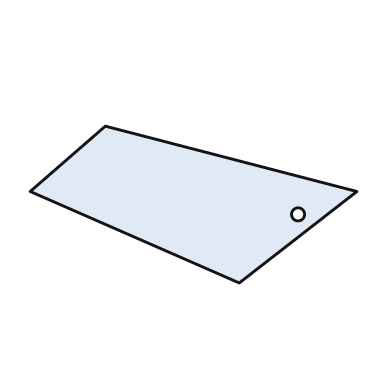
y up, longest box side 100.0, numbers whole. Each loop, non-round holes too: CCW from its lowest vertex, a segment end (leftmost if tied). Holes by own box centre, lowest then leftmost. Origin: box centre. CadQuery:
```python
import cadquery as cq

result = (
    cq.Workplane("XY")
    .moveTo(14.0, -24.0)
    .lineTo(50.0, 4.0)
    .lineTo(-27.0, 24.0)
    .lineTo(-50.0, 4.0)
    .close()
    .moveTo(32.0, -3.0)
    .circle(2.0)
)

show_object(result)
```